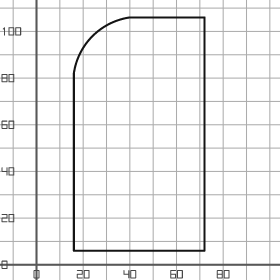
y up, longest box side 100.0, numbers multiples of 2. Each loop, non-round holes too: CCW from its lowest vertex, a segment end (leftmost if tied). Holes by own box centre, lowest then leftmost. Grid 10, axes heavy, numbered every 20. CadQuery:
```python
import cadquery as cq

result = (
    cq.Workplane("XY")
    .moveTo(16.0, 6.0)
    .lineTo(72.0, 6.0)
    .lineTo(72.0, 106.0)
    .lineTo(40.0, 106.0)
    .threePointArc((24.0, 98.0), (16.0, 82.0))
    .close()
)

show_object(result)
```